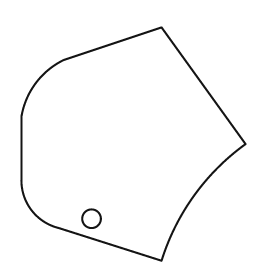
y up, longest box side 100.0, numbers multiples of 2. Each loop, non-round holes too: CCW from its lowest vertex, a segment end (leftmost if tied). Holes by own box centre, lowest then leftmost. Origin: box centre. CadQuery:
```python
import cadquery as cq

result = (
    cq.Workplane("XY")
    .moveTo(12.0, -50.0)
    .threePointArc((26.0, -22.0), (48.0, 0.0))
    .lineTo(12.0, 50.0)
    .lineTo(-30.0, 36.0)
    .threePointArc((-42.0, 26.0), (-48.0, 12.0))
    .lineTo(-48.0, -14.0)
    .threePointArc((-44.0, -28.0), (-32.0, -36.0))
    .close()
    .moveTo(-18.0, -32.0)
    .circle(4.0)
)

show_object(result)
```